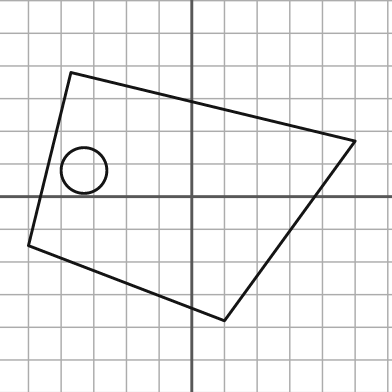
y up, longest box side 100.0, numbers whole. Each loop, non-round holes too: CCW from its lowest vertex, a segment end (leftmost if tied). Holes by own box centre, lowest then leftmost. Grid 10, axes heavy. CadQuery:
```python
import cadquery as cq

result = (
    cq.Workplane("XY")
    .moveTo(10.0, -38.0)
    .lineTo(50.0, 17.0)
    .lineTo(-37.0, 38.0)
    .lineTo(-50.0, -15.0)
    .close()
    .moveTo(-33.0, 8.0)
    .circle(7.0)
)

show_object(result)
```